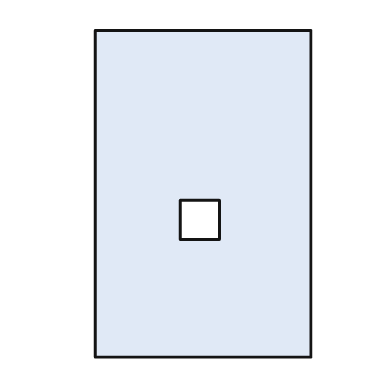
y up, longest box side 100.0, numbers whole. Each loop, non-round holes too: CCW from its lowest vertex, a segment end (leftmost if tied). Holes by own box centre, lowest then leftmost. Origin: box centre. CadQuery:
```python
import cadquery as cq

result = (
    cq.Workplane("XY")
    .moveTo(-33.0, -50.0)
    .lineTo(33.0, -50.0)
    .lineTo(33.0, 50.0)
    .lineTo(-33.0, 50.0)
    .close()
    .moveTo(-7.0, -14.0)
    .lineTo(5.0, -14.0)
    .lineTo(5.0, -2.0)
    .lineTo(-7.0, -2.0)
    .close()
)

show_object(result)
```